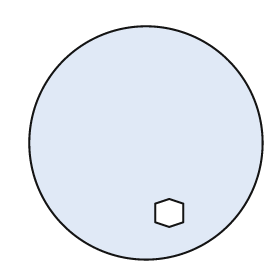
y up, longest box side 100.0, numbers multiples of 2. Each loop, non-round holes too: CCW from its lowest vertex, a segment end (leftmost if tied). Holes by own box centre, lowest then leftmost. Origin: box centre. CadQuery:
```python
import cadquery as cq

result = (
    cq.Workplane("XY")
    .moveTo(0.0, 0.0)
    .circle(50.0)
    .moveTo(10.0, -36.0)
    .lineTo(16.0, -34.0)
    .lineTo(16.0, -26.0)
    .lineTo(10.0, -24.0)
    .lineTo(4.0, -26.0)
    .lineTo(4.0, -34.0)
    .close()
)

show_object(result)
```